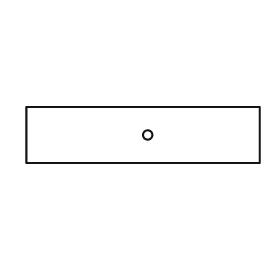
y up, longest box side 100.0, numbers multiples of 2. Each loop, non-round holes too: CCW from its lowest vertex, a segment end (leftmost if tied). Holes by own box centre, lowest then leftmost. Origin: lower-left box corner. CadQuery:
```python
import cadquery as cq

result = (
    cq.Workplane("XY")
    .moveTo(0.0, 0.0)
    .lineTo(100.0, 0.0)
    .lineTo(100.0, 24.0)
    .lineTo(0.0, 24.0)
    .close()
    .moveTo(52.0, 12.0)
    .circle(2.0)
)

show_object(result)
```